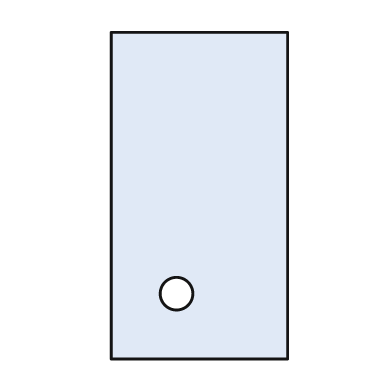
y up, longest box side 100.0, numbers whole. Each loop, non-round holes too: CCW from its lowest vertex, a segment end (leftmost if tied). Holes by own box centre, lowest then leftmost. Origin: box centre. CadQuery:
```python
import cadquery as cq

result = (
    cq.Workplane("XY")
    .moveTo(-27.0, -50.0)
    .lineTo(27.0, -50.0)
    .lineTo(27.0, 50.0)
    .lineTo(-27.0, 50.0)
    .close()
    .moveTo(-7.0, -30.0)
    .circle(5.0)
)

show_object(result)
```